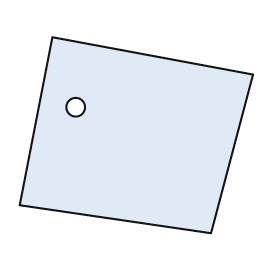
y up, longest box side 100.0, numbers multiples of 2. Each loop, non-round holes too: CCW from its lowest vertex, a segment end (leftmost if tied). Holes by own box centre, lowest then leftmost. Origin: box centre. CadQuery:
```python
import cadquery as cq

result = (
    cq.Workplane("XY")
    .moveTo(32.0, -42.0)
    .lineTo(50.0, 26.0)
    .lineTo(-36.0, 42.0)
    .lineTo(-50.0, -30.0)
    .close()
    .moveTo(-26.0, 12.0)
    .circle(4.0)
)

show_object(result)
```